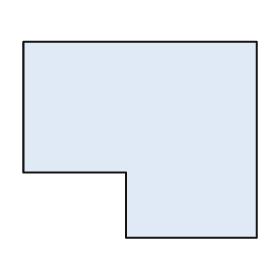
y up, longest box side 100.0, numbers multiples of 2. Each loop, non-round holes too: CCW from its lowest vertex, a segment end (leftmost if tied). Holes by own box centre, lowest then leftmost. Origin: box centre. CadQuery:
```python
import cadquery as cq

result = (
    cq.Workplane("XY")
    .moveTo(-6.0, -42.0)
    .lineTo(50.0, -42.0)
    .lineTo(50.0, 42.0)
    .lineTo(-50.0, 42.0)
    .lineTo(-50.0, -14.0)
    .lineTo(-6.0, -14.0)
    .close()
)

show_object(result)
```